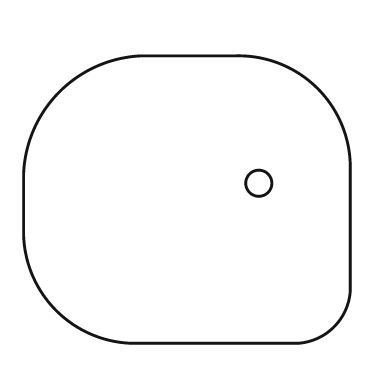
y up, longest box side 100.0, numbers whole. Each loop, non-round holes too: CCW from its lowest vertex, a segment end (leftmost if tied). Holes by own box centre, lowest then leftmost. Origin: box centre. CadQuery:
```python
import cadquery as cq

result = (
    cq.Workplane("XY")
    .moveTo(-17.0, -44.0)
    .lineTo(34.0, -44.0)
    .threePointArc((45.0, -39.0), (50.0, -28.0))
    .lineTo(50.0, 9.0)
    .threePointArc((40.0, 34.0), (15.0, 44.0))
    .lineTo(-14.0, 44.0)
    .threePointArc((-39.0, 33.0), (-50.0, 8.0))
    .lineTo(-50.0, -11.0)
    .threePointArc((-40.0, -34.0), (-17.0, -44.0))
    .close()
    .moveTo(22.0, 5.0)
    .circle(4.0)
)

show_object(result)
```